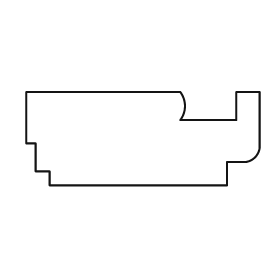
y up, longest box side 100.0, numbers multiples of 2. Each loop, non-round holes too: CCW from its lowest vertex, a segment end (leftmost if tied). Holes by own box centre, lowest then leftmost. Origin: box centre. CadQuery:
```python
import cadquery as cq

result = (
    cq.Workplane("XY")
    .moveTo(-40.0, -20.0)
    .lineTo(36.0, -20.0)
    .lineTo(36.0, -10.0)
    .lineTo(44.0, -10.0)
    .threePointArc((48.0, -8.0), (50.0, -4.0))
    .lineTo(50.0, 20.0)
    .lineTo(40.0, 20.0)
    .lineTo(40.0, 8.0)
    .lineTo(16.0, 8.0)
    .threePointArc((18.0, 14.0), (16.0, 20.0))
    .lineTo(-50.0, 20.0)
    .lineTo(-50.0, -2.0)
    .lineTo(-46.0, -2.0)
    .lineTo(-46.0, -14.0)
    .lineTo(-40.0, -14.0)
    .close()
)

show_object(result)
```